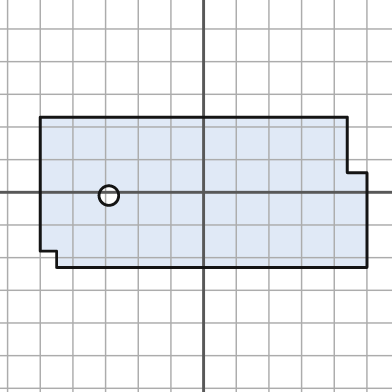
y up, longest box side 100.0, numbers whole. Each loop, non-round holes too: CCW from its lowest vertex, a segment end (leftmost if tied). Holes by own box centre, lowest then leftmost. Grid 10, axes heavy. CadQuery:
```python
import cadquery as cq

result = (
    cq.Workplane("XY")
    .moveTo(-45.0, -23.0)
    .lineTo(50.0, -23.0)
    .lineTo(50.0, 6.0)
    .lineTo(44.0, 6.0)
    .lineTo(44.0, 23.0)
    .lineTo(-50.0, 23.0)
    .lineTo(-50.0, -18.0)
    .lineTo(-45.0, -18.0)
    .close()
    .moveTo(-29.0, -1.0)
    .circle(3.0)
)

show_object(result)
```